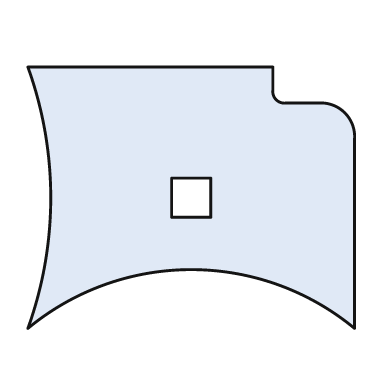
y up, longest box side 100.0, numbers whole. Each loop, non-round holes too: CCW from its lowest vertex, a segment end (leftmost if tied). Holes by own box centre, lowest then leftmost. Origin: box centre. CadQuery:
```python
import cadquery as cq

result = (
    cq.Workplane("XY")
    .moveTo(-50.0, -40.0)
    .threePointArc((0.0, -22.0), (50.0, -40.0))
    .lineTo(50.0, 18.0)
    .threePointArc((47.0, 26.0), (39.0, 29.0))
    .lineTo(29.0, 29.0)
    .threePointArc((26.0, 30.0), (25.0, 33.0))
    .lineTo(25.0, 40.0)
    .lineTo(-50.0, 40.0)
    .threePointArc((-43.0, 0.0), (-50.0, -40.0))
    .close()
    .moveTo(-6.0, -6.0)
    .lineTo(6.0, -6.0)
    .lineTo(6.0, 6.0)
    .lineTo(-6.0, 6.0)
    .close()
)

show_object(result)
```